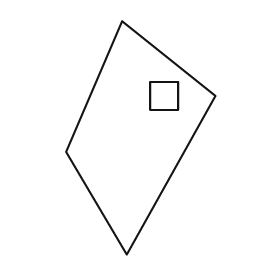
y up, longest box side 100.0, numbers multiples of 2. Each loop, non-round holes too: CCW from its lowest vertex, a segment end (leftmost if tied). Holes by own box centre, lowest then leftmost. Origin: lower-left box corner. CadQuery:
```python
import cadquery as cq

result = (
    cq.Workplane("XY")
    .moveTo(26.0, 0.0)
    .lineTo(64.0, 68.0)
    .lineTo(24.0, 100.0)
    .lineTo(0.0, 44.0)
    .close()
    .moveTo(36.0, 62.0)
    .lineTo(48.0, 62.0)
    .lineTo(48.0, 74.0)
    .lineTo(36.0, 74.0)
    .close()
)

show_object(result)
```